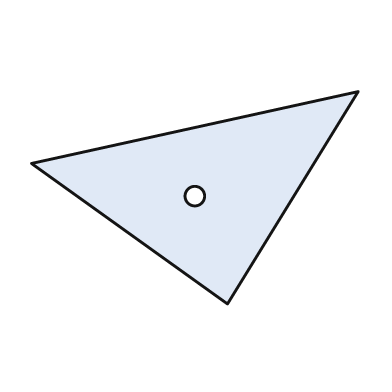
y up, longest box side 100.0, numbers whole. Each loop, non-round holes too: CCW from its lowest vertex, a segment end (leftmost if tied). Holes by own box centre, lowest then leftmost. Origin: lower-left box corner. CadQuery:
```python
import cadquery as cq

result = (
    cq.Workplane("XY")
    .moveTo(60.0, 0.0)
    .lineTo(100.0, 65.0)
    .lineTo(0.0, 43.0)
    .close()
    .moveTo(50.0, 33.0)
    .circle(3.0)
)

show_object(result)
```